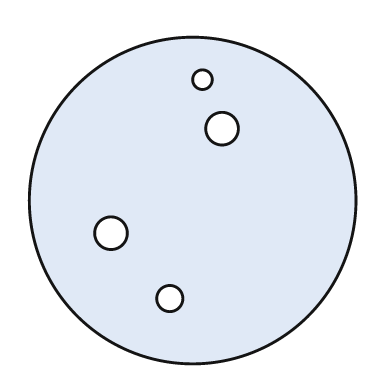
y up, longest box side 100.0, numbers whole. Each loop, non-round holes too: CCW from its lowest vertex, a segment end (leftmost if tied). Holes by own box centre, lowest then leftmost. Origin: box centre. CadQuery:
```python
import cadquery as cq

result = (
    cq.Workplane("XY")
    .moveTo(0.0, 0.0)
    .circle(50.0)
    .moveTo(-7.0, -30.0)
    .circle(4.0)
    .moveTo(-25.0, -10.0)
    .circle(5.0)
    .moveTo(9.0, 22.0)
    .circle(5.0)
    .moveTo(3.0, 37.0)
    .circle(3.0)
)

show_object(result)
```